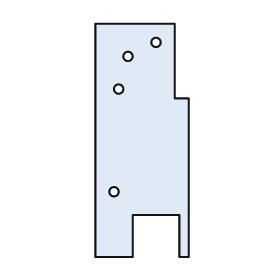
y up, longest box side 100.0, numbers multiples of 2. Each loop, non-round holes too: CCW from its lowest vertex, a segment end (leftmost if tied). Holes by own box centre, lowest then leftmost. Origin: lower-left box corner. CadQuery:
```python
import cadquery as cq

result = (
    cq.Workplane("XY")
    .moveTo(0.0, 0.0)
    .lineTo(16.0, 0.0)
    .lineTo(16.0, 18.0)
    .lineTo(36.0, 18.0)
    .lineTo(36.0, 0.0)
    .lineTo(40.0, 0.0)
    .lineTo(40.0, 68.0)
    .lineTo(34.0, 68.0)
    .lineTo(34.0, 100.0)
    .lineTo(0.0, 100.0)
    .close()
    .moveTo(8.0, 28.0)
    .circle(2.0)
    .moveTo(10.0, 72.0)
    .circle(2.0)
    .moveTo(14.0, 86.0)
    .circle(2.0)
    .moveTo(26.0, 92.0)
    .circle(2.0)
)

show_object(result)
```